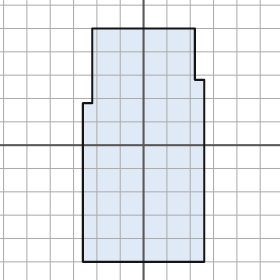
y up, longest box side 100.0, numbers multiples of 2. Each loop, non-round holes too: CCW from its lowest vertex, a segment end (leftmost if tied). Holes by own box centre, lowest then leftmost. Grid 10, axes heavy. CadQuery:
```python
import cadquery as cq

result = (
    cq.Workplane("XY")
    .moveTo(-26.0, -50.0)
    .lineTo(26.0, -50.0)
    .lineTo(26.0, 28.0)
    .lineTo(22.0, 28.0)
    .lineTo(22.0, 50.0)
    .lineTo(-22.0, 50.0)
    .lineTo(-22.0, 18.0)
    .lineTo(-26.0, 18.0)
    .close()
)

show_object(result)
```